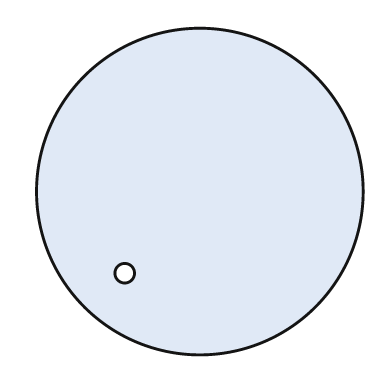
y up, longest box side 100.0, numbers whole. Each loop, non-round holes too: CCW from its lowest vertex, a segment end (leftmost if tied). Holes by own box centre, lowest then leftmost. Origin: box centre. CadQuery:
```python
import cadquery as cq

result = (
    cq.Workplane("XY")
    .moveTo(0.0, 0.0)
    .circle(50.0)
    .moveTo(-23.0, -25.0)
    .circle(3.0)
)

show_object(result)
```